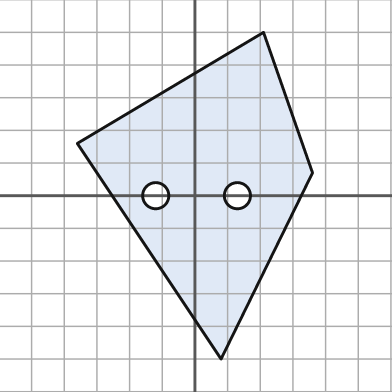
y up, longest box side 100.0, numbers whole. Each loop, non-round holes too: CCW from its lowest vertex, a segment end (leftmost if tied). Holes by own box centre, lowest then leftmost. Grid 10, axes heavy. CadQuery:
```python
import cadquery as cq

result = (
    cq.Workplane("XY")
    .moveTo(8.0, -50.0)
    .lineTo(36.0, 7.0)
    .lineTo(21.0, 50.0)
    .lineTo(-36.0, 16.0)
    .close()
    .moveTo(-12.0, 0.0)
    .circle(4.0)
    .moveTo(13.0, 0.0)
    .circle(4.0)
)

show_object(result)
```